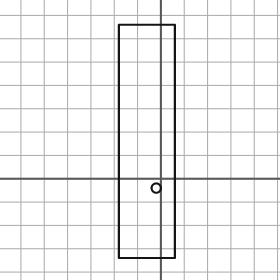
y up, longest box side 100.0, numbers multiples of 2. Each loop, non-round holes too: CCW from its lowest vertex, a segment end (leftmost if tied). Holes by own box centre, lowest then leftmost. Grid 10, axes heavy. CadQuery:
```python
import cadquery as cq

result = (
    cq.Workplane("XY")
    .moveTo(-18.0, -34.0)
    .lineTo(6.0, -34.0)
    .lineTo(6.0, 66.0)
    .lineTo(-18.0, 66.0)
    .close()
    .moveTo(-2.0, -4.0)
    .circle(2.0)
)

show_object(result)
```